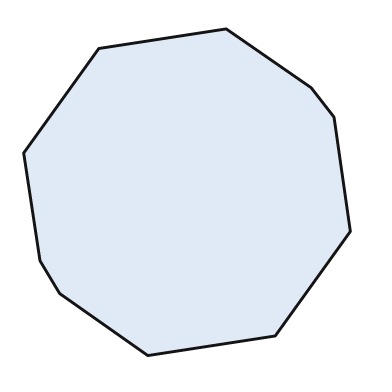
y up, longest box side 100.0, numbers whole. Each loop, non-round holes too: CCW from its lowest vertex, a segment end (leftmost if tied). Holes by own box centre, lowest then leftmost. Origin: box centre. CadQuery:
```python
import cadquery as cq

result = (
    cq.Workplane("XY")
    .moveTo(-12.0, -50.0)
    .lineTo(27.0, -44.0)
    .lineTo(50.0, -12.0)
    .lineTo(45.0, 23.0)
    .lineTo(38.0, 32.0)
    .lineTo(12.0, 50.0)
    .lineTo(-27.0, 44.0)
    .lineTo(-50.0, 12.0)
    .lineTo(-45.0, -21.0)
    .lineTo(-39.0, -31.0)
    .close()
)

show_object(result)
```